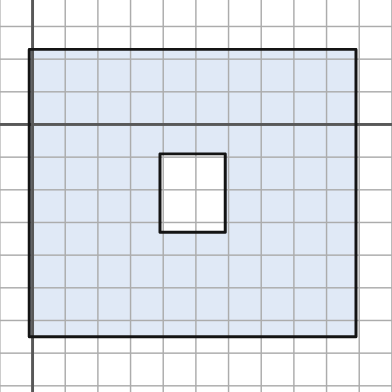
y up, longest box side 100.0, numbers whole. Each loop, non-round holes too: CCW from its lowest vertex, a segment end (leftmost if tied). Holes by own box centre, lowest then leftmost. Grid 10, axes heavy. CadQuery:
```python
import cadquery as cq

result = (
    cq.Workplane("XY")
    .moveTo(-1.0, -65.0)
    .lineTo(99.0, -65.0)
    .lineTo(99.0, 23.0)
    .lineTo(-1.0, 23.0)
    .close()
    .moveTo(39.0, -33.0)
    .lineTo(59.0, -33.0)
    .lineTo(59.0, -9.0)
    .lineTo(39.0, -9.0)
    .close()
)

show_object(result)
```